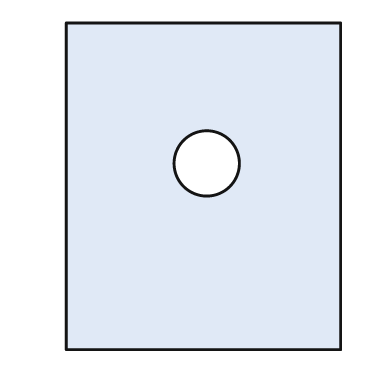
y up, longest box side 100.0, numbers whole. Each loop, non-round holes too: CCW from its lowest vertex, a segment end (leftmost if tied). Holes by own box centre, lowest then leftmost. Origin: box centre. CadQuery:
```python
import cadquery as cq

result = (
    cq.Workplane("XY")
    .moveTo(-42.0, -50.0)
    .lineTo(42.0, -50.0)
    .lineTo(42.0, 50.0)
    .lineTo(-42.0, 50.0)
    .close()
    .moveTo(1.0, 7.0)
    .circle(10.0)
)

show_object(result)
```